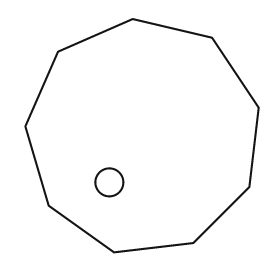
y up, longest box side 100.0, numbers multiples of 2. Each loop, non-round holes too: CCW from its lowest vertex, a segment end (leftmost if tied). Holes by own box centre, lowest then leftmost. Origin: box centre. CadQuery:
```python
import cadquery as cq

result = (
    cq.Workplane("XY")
    .moveTo(-12.0, -50.0)
    .lineTo(22.0, -46.0)
    .lineTo(46.0, -22.0)
    .lineTo(50.0, 12.0)
    .lineTo(30.0, 42.0)
    .lineTo(-4.0, 50.0)
    .lineTo(-36.0, 36.0)
    .lineTo(-50.0, 4.0)
    .lineTo(-40.0, -30.0)
    .close()
    .moveTo(-14.0, -20.0)
    .circle(6.0)
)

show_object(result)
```